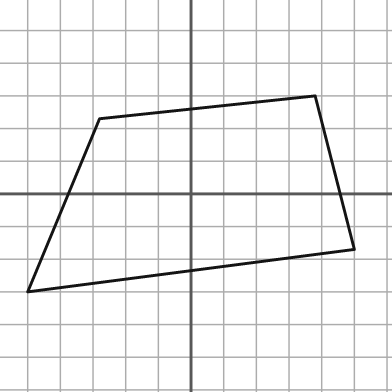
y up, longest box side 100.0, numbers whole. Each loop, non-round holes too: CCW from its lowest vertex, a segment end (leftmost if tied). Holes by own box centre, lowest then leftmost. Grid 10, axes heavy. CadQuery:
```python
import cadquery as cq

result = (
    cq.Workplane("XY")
    .moveTo(-50.0, -30.0)
    .lineTo(50.0, -17.0)
    .lineTo(38.0, 30.0)
    .lineTo(-28.0, 23.0)
    .close()
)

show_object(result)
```